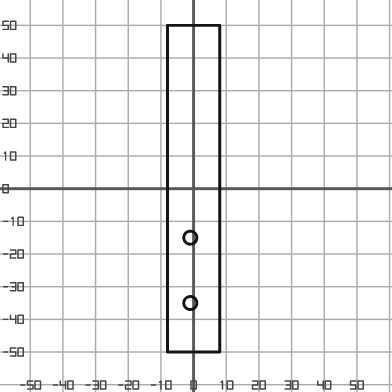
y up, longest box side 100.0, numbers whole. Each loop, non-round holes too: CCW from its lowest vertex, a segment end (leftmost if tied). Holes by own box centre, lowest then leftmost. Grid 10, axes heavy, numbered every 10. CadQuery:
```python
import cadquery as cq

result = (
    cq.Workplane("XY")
    .moveTo(-8.0, -50.0)
    .lineTo(8.0, -50.0)
    .lineTo(8.0, 50.0)
    .lineTo(-8.0, 50.0)
    .close()
    .moveTo(-1.0, -35.0)
    .circle(2.0)
    .moveTo(-1.0, -15.0)
    .circle(2.0)
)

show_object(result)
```